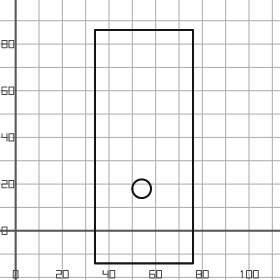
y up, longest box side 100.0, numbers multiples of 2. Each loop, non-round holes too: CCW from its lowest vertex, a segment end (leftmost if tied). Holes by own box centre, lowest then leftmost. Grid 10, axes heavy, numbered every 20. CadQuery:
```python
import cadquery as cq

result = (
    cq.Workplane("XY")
    .moveTo(34.0, -14.0)
    .lineTo(76.0, -14.0)
    .lineTo(76.0, 86.0)
    .lineTo(34.0, 86.0)
    .close()
    .moveTo(54.0, 18.0)
    .circle(4.0)
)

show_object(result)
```